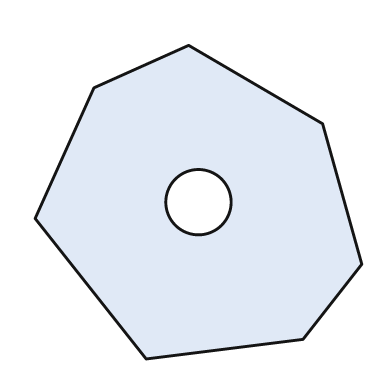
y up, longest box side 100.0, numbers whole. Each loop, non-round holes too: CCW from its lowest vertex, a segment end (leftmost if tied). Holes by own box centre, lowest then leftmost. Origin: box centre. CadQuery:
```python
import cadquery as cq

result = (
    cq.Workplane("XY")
    .moveTo(-16.0, -48.0)
    .lineTo(32.0, -42.0)
    .lineTo(50.0, -19.0)
    .lineTo(38.0, 24.0)
    .lineTo(-3.0, 48.0)
    .lineTo(-32.0, 35.0)
    .lineTo(-50.0, -5.0)
    .close()
    .moveTo(0.0, 0.0)
    .circle(10.0)
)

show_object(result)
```